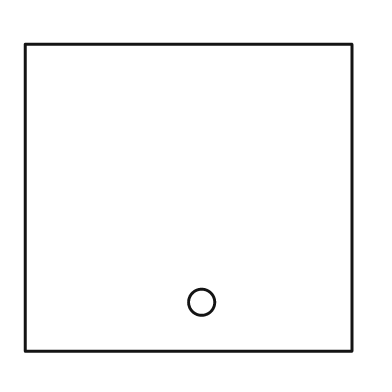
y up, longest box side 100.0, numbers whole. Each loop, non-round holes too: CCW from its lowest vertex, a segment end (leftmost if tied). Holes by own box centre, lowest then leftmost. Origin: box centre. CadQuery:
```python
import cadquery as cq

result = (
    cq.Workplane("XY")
    .moveTo(-50.0, -47.0)
    .lineTo(50.0, -47.0)
    .lineTo(50.0, 47.0)
    .lineTo(-50.0, 47.0)
    .close()
    .moveTo(4.0, -32.0)
    .circle(4.0)
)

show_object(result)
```